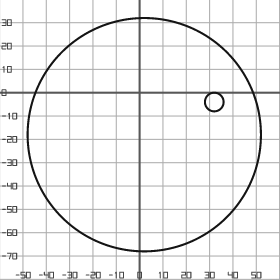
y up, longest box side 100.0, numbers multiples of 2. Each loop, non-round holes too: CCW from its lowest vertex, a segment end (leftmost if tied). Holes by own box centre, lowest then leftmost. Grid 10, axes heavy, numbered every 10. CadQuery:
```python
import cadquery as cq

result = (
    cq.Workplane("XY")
    .moveTo(2.0, -18.0)
    .circle(50.0)
    .moveTo(32.0, -4.0)
    .circle(4.0)
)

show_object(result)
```